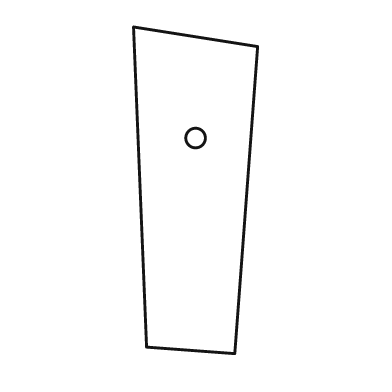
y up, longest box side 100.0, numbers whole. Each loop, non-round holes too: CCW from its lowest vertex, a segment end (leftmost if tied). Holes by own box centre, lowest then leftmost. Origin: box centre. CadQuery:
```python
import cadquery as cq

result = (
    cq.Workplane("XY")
    .moveTo(12.0, -50.0)
    .lineTo(19.0, 44.0)
    .lineTo(-19.0, 50.0)
    .lineTo(-15.0, -48.0)
    .close()
    .moveTo(0.0, 16.0)
    .circle(3.0)
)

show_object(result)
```